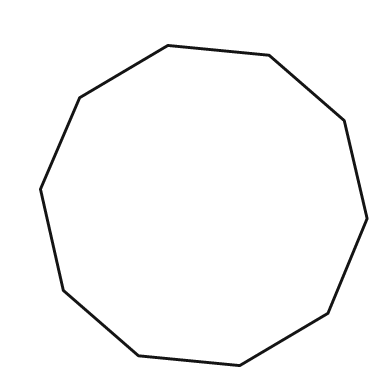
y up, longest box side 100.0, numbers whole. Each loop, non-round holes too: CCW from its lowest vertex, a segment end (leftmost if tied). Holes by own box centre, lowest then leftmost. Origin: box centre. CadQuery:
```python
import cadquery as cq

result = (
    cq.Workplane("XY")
    .moveTo(11.0, -49.0)
    .lineTo(38.0, -33.0)
    .lineTo(50.0, -4.0)
    .lineTo(43.0, 26.0)
    .lineTo(20.0, 46.0)
    .lineTo(-11.0, 49.0)
    .lineTo(-38.0, 33.0)
    .lineTo(-50.0, 5.0)
    .lineTo(-43.0, -26.0)
    .lineTo(-20.0, -46.0)
    .close()
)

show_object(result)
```